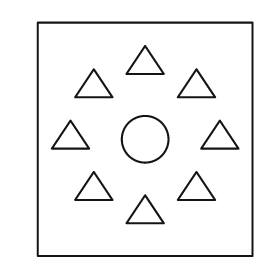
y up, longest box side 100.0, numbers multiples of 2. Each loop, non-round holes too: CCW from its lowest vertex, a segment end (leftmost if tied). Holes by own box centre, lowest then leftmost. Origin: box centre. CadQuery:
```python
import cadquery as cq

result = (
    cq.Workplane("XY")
    .moveTo(-46.0, -50.0)
    .lineTo(46.0, -50.0)
    .lineTo(46.0, 50.0)
    .lineTo(-46.0, 50.0)
    .close()
    .moveTo(-8.0, -36.0)
    .lineTo(8.0, -36.0)
    .lineTo(0.0, -24.0)
    .close()
    .moveTo(-30.0, -26.0)
    .lineTo(-14.0, -26.0)
    .lineTo(-22.0, -14.0)
    .close()
    .moveTo(14.0, -26.0)
    .lineTo(30.0, -26.0)
    .lineTo(22.0, -14.0)
    .close()
    .moveTo(0.0, 0.0)
    .circle(10.0)
    .moveTo(-40.0, -4.0)
    .lineTo(-24.0, -4.0)
    .lineTo(-32.0, 8.0)
    .close()
    .moveTo(24.0, -4.0)
    .lineTo(40.0, -4.0)
    .lineTo(32.0, 8.0)
    .close()
    .moveTo(-30.0, 18.0)
    .lineTo(-14.0, 18.0)
    .lineTo(-22.0, 30.0)
    .close()
    .moveTo(14.0, 18.0)
    .lineTo(30.0, 18.0)
    .lineTo(22.0, 30.0)
    .close()
    .moveTo(-8.0, 28.0)
    .lineTo(8.0, 28.0)
    .lineTo(0.0, 40.0)
    .close()
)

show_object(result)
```